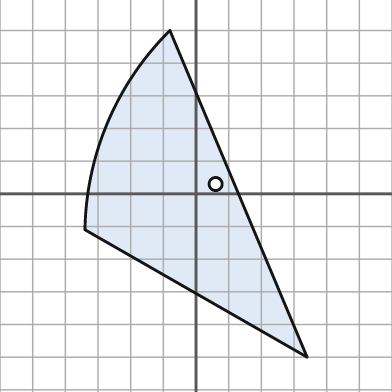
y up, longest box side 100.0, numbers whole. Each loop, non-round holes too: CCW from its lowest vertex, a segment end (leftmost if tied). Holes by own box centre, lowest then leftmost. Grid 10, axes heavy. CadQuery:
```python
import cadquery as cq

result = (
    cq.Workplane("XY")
    .moveTo(34.0, -50.0)
    .lineTo(-8.0, 50.0)
    .threePointArc((-27.0, 22.0), (-34.0, -11.0))
    .close()
    .moveTo(6.0, 3.0)
    .circle(2.0)
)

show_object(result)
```